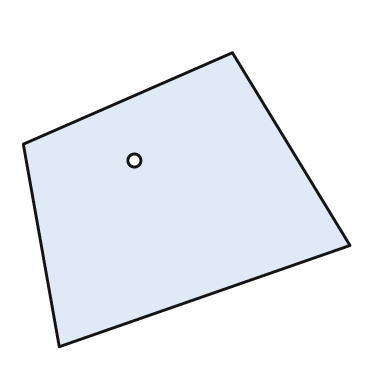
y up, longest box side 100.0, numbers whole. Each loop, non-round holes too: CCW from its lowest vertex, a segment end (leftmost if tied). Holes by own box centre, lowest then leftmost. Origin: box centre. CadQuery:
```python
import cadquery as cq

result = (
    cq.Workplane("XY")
    .moveTo(-39.0, -45.0)
    .lineTo(50.0, -14.0)
    .lineTo(14.0, 45.0)
    .lineTo(-50.0, 17.0)
    .close()
    .moveTo(-16.0, 12.0)
    .circle(2.0)
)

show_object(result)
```